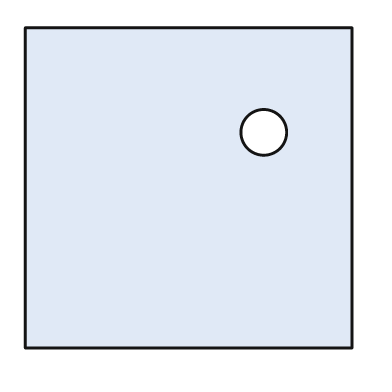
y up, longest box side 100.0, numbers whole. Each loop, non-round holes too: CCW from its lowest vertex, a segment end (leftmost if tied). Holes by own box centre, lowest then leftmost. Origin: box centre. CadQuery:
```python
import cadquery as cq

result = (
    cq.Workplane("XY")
    .moveTo(-50.0, -49.0)
    .lineTo(50.0, -49.0)
    .lineTo(50.0, 49.0)
    .lineTo(-50.0, 49.0)
    .close()
    .moveTo(23.0, 17.0)
    .circle(7.0)
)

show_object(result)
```